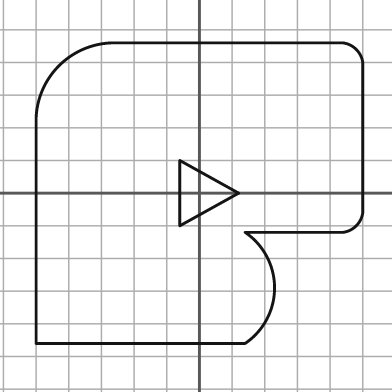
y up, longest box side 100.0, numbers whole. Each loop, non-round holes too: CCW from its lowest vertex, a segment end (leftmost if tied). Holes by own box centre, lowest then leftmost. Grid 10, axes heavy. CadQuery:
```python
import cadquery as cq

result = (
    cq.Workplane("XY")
    .moveTo(-50.0, -46.0)
    .lineTo(14.0, -46.0)
    .threePointArc((23.0, -29.0), (14.0, -12.0))
    .lineTo(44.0, -12.0)
    .threePointArc((48.0, -10.0), (50.0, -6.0))
    .lineTo(50.0, 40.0)
    .threePointArc((48.0, 44.0), (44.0, 46.0))
    .lineTo(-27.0, 46.0)
    .threePointArc((-43.0, 39.0), (-50.0, 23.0))
    .close()
    .moveTo(-6.0, -10.0)
    .lineTo(12.0, 0.0)
    .lineTo(-6.0, 10.0)
    .close()
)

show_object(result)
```